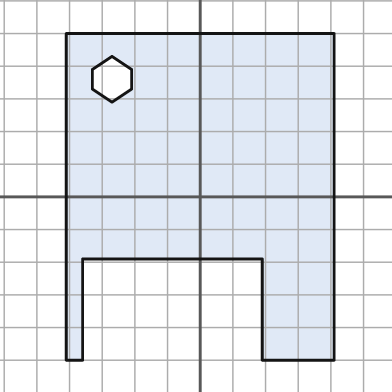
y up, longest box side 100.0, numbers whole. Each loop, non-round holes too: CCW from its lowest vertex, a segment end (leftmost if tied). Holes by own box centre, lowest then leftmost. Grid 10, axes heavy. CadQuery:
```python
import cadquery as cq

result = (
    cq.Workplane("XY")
    .moveTo(-41.0, -50.0)
    .lineTo(-36.0, -50.0)
    .lineTo(-36.0, -19.0)
    .lineTo(19.0, -19.0)
    .lineTo(19.0, -50.0)
    .lineTo(41.0, -50.0)
    .lineTo(41.0, 50.0)
    .lineTo(-41.0, 50.0)
    .close()
    .moveTo(-27.0, 29.0)
    .lineTo(-21.0, 33.0)
    .lineTo(-21.0, 39.0)
    .lineTo(-27.0, 43.0)
    .lineTo(-33.0, 39.0)
    .lineTo(-33.0, 33.0)
    .close()
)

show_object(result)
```